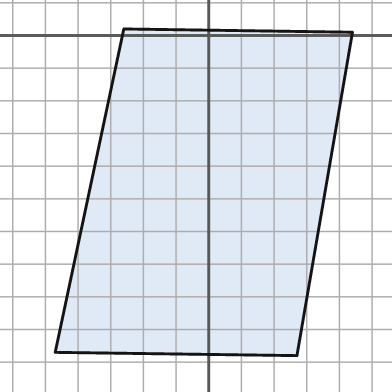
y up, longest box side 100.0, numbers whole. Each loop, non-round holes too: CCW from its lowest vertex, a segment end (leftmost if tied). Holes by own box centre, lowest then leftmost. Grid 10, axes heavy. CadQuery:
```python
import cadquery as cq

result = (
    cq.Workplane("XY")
    .moveTo(27.0, -98.0)
    .lineTo(44.0, 1.0)
    .lineTo(-26.0, 2.0)
    .lineTo(-47.0, -97.0)
    .close()
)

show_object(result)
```